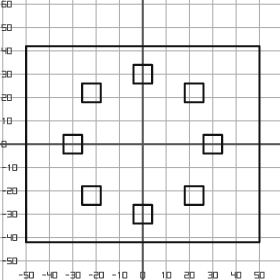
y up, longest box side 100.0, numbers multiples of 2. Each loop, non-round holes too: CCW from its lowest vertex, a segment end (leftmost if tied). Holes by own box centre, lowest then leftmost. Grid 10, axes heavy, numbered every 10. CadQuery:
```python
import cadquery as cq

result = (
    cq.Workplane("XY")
    .moveTo(-50.0, -42.0)
    .lineTo(50.0, -42.0)
    .lineTo(50.0, 42.0)
    .lineTo(-50.0, 42.0)
    .close()
    .moveTo(-4.0, -34.0)
    .lineTo(4.0, -34.0)
    .lineTo(4.0, -26.0)
    .lineTo(-4.0, -26.0)
    .close()
    .moveTo(-26.0, -26.0)
    .lineTo(-18.0, -26.0)
    .lineTo(-18.0, -18.0)
    .lineTo(-26.0, -18.0)
    .close()
    .moveTo(18.0, -26.0)
    .lineTo(26.0, -26.0)
    .lineTo(26.0, -18.0)
    .lineTo(18.0, -18.0)
    .close()
    .moveTo(-34.0, -4.0)
    .lineTo(-26.0, -4.0)
    .lineTo(-26.0, 4.0)
    .lineTo(-34.0, 4.0)
    .close()
    .moveTo(26.0, -4.0)
    .lineTo(34.0, -4.0)
    .lineTo(34.0, 4.0)
    .lineTo(26.0, 4.0)
    .close()
    .moveTo(-26.0, 18.0)
    .lineTo(-18.0, 18.0)
    .lineTo(-18.0, 26.0)
    .lineTo(-26.0, 26.0)
    .close()
    .moveTo(18.0, 18.0)
    .lineTo(26.0, 18.0)
    .lineTo(26.0, 26.0)
    .lineTo(18.0, 26.0)
    .close()
    .moveTo(-4.0, 26.0)
    .lineTo(4.0, 26.0)
    .lineTo(4.0, 34.0)
    .lineTo(-4.0, 34.0)
    .close()
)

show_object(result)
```